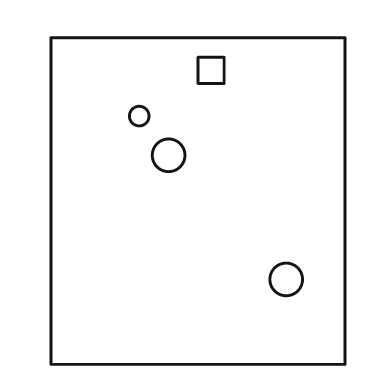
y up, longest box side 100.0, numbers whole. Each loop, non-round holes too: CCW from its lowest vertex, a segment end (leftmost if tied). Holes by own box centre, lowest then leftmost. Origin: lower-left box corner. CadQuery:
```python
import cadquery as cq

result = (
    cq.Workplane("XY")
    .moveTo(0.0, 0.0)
    .lineTo(90.0, 0.0)
    .lineTo(90.0, 100.0)
    .lineTo(0.0, 100.0)
    .close()
    .moveTo(72.0, 26.0)
    .circle(5.0)
    .moveTo(36.0, 64.0)
    .circle(5.0)
    .moveTo(27.0, 76.0)
    .circle(3.0)
    .moveTo(45.0, 86.0)
    .lineTo(53.0, 86.0)
    .lineTo(53.0, 94.0)
    .lineTo(45.0, 94.0)
    .close()
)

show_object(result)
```